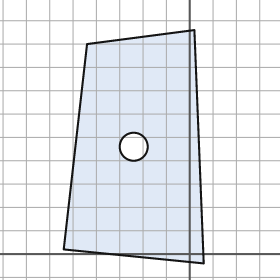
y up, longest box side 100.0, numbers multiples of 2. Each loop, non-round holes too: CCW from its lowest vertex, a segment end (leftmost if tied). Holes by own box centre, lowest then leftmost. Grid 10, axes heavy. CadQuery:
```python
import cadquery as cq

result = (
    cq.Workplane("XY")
    .moveTo(6.0, -4.0)
    .lineTo(2.0, 96.0)
    .lineTo(-44.0, 90.0)
    .lineTo(-54.0, 2.0)
    .close()
    .moveTo(-24.0, 46.0)
    .circle(6.0)
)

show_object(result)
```